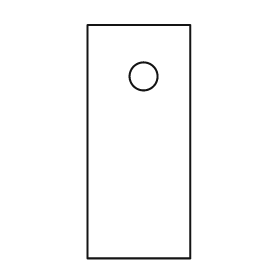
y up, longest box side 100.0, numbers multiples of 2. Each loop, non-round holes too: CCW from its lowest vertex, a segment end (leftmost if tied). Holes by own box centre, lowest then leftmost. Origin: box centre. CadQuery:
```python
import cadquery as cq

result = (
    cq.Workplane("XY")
    .moveTo(-22.0, -50.0)
    .lineTo(22.0, -50.0)
    .lineTo(22.0, 50.0)
    .lineTo(-22.0, 50.0)
    .close()
    .moveTo(2.0, 28.0)
    .circle(6.0)
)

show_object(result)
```